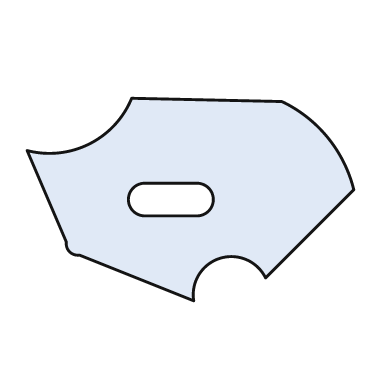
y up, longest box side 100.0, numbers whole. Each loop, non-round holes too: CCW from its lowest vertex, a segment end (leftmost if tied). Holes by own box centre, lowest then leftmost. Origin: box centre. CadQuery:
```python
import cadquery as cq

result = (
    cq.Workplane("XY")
    .moveTo(1.0, -31.0)
    .threePointArc((9.0, -18.0), (23.0, -24.0))
    .lineTo(50.0, 3.0)
    .threePointArc((42.0, 19.0), (28.0, 30.0))
    .lineTo(-18.0, 31.0)
    .threePointArc((-31.0, 17.0), (-50.0, 15.0))
    .lineTo(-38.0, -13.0)
    .threePointArc((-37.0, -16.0), (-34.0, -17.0))
    .close()
    .moveTo(-14.0, -5.0)
    .lineTo(2.0, -5.0)
    .threePointArc((7.0, 0.0), (2.0, 5.0))
    .lineTo(-14.0, 5.0)
    .threePointArc((-19.0, 0.0), (-14.0, -5.0))
    .close()
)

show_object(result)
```